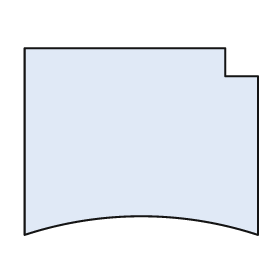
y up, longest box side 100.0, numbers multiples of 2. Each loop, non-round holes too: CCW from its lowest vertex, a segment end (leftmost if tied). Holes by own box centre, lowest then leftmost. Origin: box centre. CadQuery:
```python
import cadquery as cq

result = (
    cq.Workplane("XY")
    .moveTo(-50.0, -40.0)
    .threePointArc((0.0, -32.0), (50.0, -40.0))
    .lineTo(50.0, 28.0)
    .lineTo(36.0, 28.0)
    .lineTo(36.0, 40.0)
    .lineTo(-50.0, 40.0)
    .close()
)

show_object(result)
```